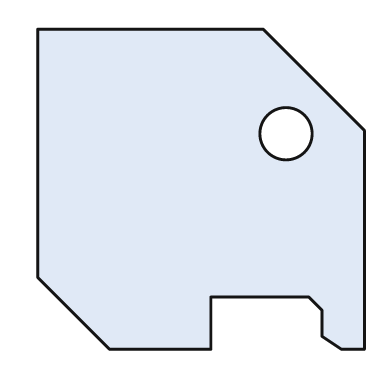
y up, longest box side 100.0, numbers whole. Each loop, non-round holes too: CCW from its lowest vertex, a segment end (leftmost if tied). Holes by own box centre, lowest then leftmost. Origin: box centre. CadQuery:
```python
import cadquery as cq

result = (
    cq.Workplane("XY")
    .moveTo(-28.0, -49.0)
    .lineTo(3.0, -49.0)
    .lineTo(3.0, -33.0)
    .lineTo(33.0, -33.0)
    .lineTo(37.0, -37.0)
    .lineTo(37.0, -45.0)
    .lineTo(43.0, -49.0)
    .lineTo(50.0, -49.0)
    .lineTo(50.0, 18.0)
    .lineTo(19.0, 49.0)
    .lineTo(-50.0, 49.0)
    .lineTo(-50.0, -27.0)
    .close()
    .moveTo(26.0, 17.0)
    .circle(8.0)
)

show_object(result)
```